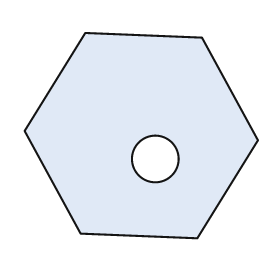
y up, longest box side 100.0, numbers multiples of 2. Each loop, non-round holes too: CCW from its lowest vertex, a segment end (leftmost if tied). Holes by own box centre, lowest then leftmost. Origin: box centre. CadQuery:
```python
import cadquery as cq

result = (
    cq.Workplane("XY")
    .moveTo(24.0, -44.0)
    .lineTo(50.0, -2.0)
    .lineTo(26.0, 42.0)
    .lineTo(-24.0, 44.0)
    .lineTo(-50.0, 2.0)
    .lineTo(-26.0, -42.0)
    .close()
    .moveTo(6.0, -10.0)
    .circle(10.0)
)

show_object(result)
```